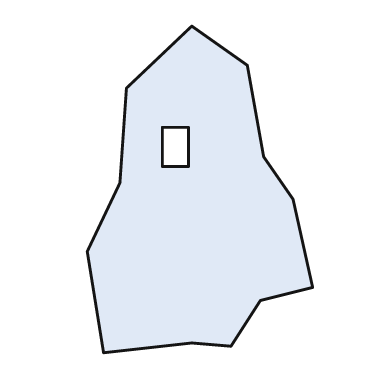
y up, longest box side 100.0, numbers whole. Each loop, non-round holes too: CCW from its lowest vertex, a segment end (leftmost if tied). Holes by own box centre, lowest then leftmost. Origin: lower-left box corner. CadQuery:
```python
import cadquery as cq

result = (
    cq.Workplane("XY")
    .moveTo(5.0, 0.0)
    .lineTo(32.0, 3.0)
    .lineTo(44.0, 2.0)
    .lineTo(53.0, 16.0)
    .lineTo(69.0, 20.0)
    .lineTo(63.0, 47.0)
    .lineTo(54.0, 60.0)
    .lineTo(49.0, 88.0)
    .lineTo(32.0, 100.0)
    .lineTo(12.0, 81.0)
    .lineTo(10.0, 52.0)
    .lineTo(0.0, 31.0)
    .close()
    .moveTo(23.0, 57.0)
    .lineTo(31.0, 57.0)
    .lineTo(31.0, 69.0)
    .lineTo(23.0, 69.0)
    .close()
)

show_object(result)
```